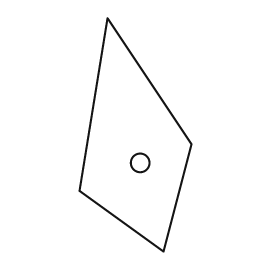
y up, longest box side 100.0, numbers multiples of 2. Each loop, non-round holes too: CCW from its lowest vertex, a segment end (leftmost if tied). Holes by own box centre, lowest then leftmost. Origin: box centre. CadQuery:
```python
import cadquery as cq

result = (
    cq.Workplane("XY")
    .moveTo(12.0, -50.0)
    .lineTo(24.0, -4.0)
    .lineTo(-12.0, 50.0)
    .lineTo(-24.0, -24.0)
    .close()
    .moveTo(2.0, -12.0)
    .circle(4.0)
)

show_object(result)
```